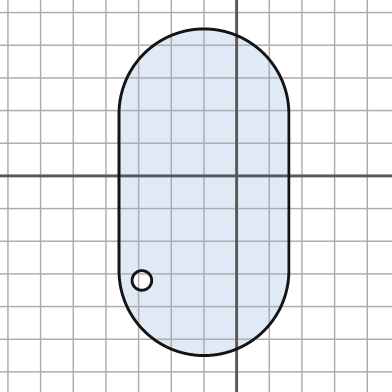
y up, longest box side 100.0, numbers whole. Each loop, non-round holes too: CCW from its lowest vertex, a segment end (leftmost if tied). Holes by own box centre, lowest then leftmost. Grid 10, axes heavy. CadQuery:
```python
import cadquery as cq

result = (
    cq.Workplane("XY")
    .moveTo(-36.0, -29.0)
    .threePointArc((-10.0, -55.0), (16.0, -29.0))
    .lineTo(16.0, 19.0)
    .threePointArc((-10.0, 45.0), (-36.0, 19.0))
    .close()
    .moveTo(-29.0, -32.0)
    .circle(3.0)
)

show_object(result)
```